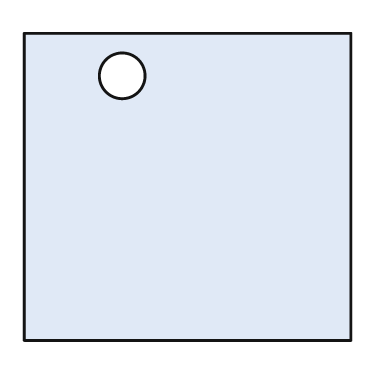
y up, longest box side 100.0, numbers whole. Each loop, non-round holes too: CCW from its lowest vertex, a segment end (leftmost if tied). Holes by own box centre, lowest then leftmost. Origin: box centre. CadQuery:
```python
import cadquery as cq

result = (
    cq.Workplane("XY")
    .moveTo(-50.0, -47.0)
    .lineTo(50.0, -47.0)
    .lineTo(50.0, 47.0)
    .lineTo(-50.0, 47.0)
    .close()
    .moveTo(-20.0, 34.0)
    .circle(7.0)
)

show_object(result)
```